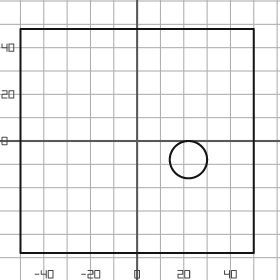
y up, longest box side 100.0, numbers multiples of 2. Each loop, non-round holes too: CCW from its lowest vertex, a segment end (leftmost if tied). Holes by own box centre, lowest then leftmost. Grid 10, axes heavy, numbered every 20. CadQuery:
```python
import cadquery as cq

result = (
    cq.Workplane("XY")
    .moveTo(-50.0, -48.0)
    .lineTo(50.0, -48.0)
    .lineTo(50.0, 48.0)
    .lineTo(-50.0, 48.0)
    .close()
    .moveTo(22.0, -8.0)
    .circle(8.0)
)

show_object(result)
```